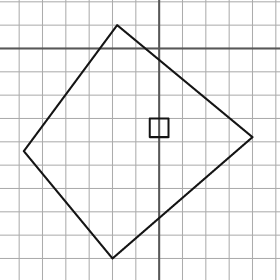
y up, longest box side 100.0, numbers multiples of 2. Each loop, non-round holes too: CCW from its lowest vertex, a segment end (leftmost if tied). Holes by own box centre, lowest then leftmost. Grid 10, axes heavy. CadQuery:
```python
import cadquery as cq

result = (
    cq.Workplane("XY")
    .moveTo(-20.0, -90.0)
    .lineTo(40.0, -38.0)
    .lineTo(-18.0, 10.0)
    .lineTo(-58.0, -44.0)
    .close()
    .moveTo(-4.0, -38.0)
    .lineTo(4.0, -38.0)
    .lineTo(4.0, -30.0)
    .lineTo(-4.0, -30.0)
    .close()
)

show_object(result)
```